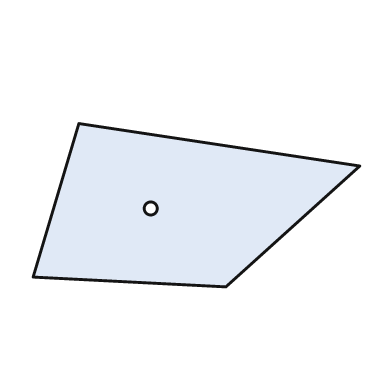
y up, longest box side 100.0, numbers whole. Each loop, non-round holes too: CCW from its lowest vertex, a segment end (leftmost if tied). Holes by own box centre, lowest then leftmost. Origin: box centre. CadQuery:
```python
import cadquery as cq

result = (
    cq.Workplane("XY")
    .moveTo(9.0, -25.0)
    .lineTo(50.0, 12.0)
    .lineTo(-36.0, 25.0)
    .lineTo(-50.0, -22.0)
    .close()
    .moveTo(-14.0, -1.0)
    .circle(2.0)
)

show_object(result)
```